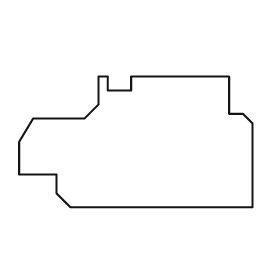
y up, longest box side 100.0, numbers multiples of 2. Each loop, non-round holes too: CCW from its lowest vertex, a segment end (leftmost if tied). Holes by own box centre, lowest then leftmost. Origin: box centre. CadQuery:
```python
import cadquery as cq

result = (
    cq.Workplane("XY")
    .moveTo(-28.0, -28.0)
    .lineTo(50.0, -28.0)
    .lineTo(50.0, 8.0)
    .lineTo(46.0, 12.0)
    .lineTo(40.0, 12.0)
    .lineTo(40.0, 28.0)
    .lineTo(-2.0, 28.0)
    .lineTo(-2.0, 22.0)
    .lineTo(-12.0, 22.0)
    .lineTo(-12.0, 28.0)
    .lineTo(-16.0, 28.0)
    .lineTo(-16.0, 16.0)
    .lineTo(-22.0, 10.0)
    .lineTo(-44.0, 10.0)
    .lineTo(-50.0, 0.0)
    .lineTo(-50.0, -14.0)
    .lineTo(-34.0, -14.0)
    .lineTo(-34.0, -22.0)
    .close()
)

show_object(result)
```